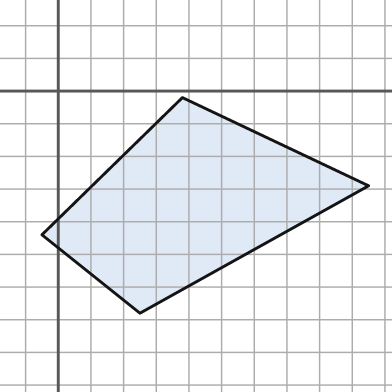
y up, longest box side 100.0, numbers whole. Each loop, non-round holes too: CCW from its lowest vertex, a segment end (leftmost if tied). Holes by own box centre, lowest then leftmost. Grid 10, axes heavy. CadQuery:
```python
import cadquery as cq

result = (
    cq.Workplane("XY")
    .moveTo(25.0, -68.0)
    .lineTo(95.0, -29.0)
    .lineTo(38.0, -2.0)
    .lineTo(-5.0, -44.0)
    .close()
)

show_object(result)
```